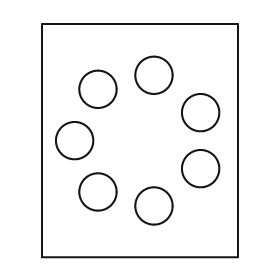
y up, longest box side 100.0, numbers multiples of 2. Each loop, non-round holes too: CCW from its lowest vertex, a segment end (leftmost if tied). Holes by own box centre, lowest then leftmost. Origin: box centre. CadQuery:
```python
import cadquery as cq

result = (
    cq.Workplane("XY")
    .moveTo(-42.0, -50.0)
    .lineTo(42.0, -50.0)
    .lineTo(42.0, 50.0)
    .lineTo(-42.0, 50.0)
    .close()
    .moveTo(6.0, -28.0)
    .circle(8.0)
    .moveTo(-18.0, -22.0)
    .circle(8.0)
    .moveTo(26.0, -12.0)
    .circle(8.0)
    .moveTo(-28.0, 0.0)
    .circle(8.0)
    .moveTo(26.0, 12.0)
    .circle(8.0)
    .moveTo(-18.0, 22.0)
    .circle(8.0)
    .moveTo(6.0, 28.0)
    .circle(8.0)
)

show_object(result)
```